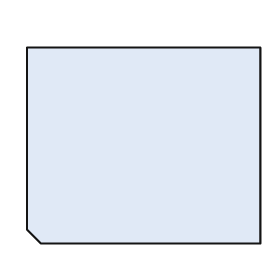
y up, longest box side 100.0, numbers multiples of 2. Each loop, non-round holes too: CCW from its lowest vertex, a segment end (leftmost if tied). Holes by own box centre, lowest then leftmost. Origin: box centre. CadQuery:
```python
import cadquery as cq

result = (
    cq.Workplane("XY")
    .moveTo(-44.0, -42.0)
    .lineTo(50.0, -42.0)
    .lineTo(50.0, 42.0)
    .lineTo(-50.0, 42.0)
    .lineTo(-50.0, -36.0)
    .close()
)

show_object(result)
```